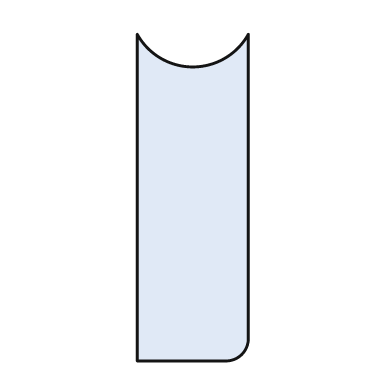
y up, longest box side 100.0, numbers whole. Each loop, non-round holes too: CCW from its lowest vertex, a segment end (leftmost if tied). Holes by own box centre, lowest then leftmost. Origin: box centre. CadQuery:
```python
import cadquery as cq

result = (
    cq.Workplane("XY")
    .moveTo(-17.0, -50.0)
    .lineTo(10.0, -50.0)
    .threePointArc((15.0, -48.0), (17.0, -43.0))
    .lineTo(17.0, 50.0)
    .threePointArc((0.0, 40.0), (-17.0, 50.0))
    .close()
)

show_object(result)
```